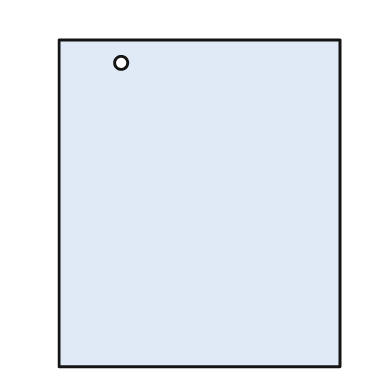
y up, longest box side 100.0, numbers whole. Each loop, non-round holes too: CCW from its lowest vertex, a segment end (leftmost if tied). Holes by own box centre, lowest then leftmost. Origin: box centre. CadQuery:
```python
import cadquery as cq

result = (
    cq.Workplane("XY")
    .moveTo(-43.0, -50.0)
    .lineTo(43.0, -50.0)
    .lineTo(43.0, 50.0)
    .lineTo(-43.0, 50.0)
    .close()
    .moveTo(-24.0, 43.0)
    .circle(2.0)
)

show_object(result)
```